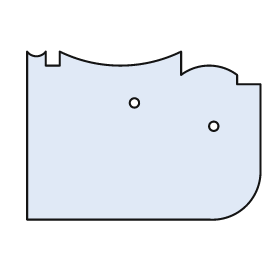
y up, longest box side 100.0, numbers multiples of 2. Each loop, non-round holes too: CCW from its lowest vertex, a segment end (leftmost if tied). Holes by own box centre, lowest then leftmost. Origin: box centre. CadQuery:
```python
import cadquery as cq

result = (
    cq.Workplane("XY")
    .moveTo(-50.0, -36.0)
    .lineTo(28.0, -36.0)
    .threePointArc((44.0, -30.0), (50.0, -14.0))
    .lineTo(50.0, 22.0)
    .lineTo(40.0, 22.0)
    .lineTo(40.0, 26.0)
    .threePointArc((28.0, 30.0), (16.0, 26.0))
    .lineTo(16.0, 36.0)
    .threePointArc((-10.0, 30.0), (-36.0, 36.0))
    .lineTo(-36.0, 30.0)
    .lineTo(-42.0, 30.0)
    .lineTo(-42.0, 36.0)
    .threePointArc((-46.0, 34.0), (-50.0, 36.0))
    .close()
    .moveTo(30.0, 4.0)
    .circle(2.0)
    .moveTo(-4.0, 14.0)
    .circle(2.0)
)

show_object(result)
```